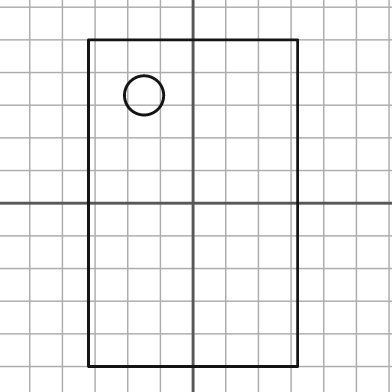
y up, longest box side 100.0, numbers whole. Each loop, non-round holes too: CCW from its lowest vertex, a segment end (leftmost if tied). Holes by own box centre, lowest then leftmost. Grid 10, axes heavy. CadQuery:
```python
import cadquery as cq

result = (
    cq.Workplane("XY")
    .moveTo(-32.0, -50.0)
    .lineTo(32.0, -50.0)
    .lineTo(32.0, 50.0)
    .lineTo(-32.0, 50.0)
    .close()
    .moveTo(-15.0, 33.0)
    .circle(6.0)
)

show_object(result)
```